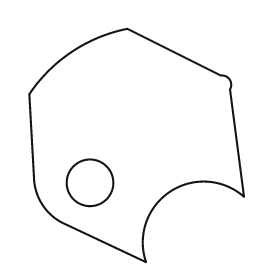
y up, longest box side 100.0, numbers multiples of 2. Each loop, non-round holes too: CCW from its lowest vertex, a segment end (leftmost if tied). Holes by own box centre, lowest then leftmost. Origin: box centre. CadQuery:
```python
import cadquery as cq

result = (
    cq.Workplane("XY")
    .moveTo(4.0, -50.0)
    .threePointArc((14.0, -20.0), (46.0, -22.0))
    .lineTo(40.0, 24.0)
    .threePointArc((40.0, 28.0), (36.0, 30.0))
    .lineTo(-4.0, 50.0)
    .threePointArc((-28.0, 40.0), (-46.0, 22.0))
    .lineTo(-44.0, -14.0)
    .threePointArc((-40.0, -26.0), (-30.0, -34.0))
    .close()
    .moveTo(-20.0, -16.0)
    .circle(10.0)
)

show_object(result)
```